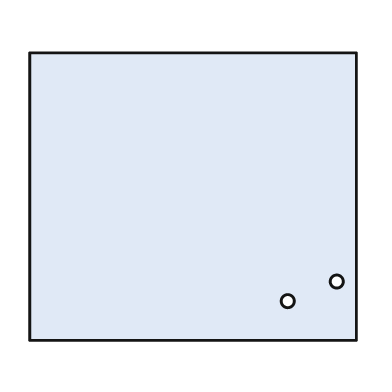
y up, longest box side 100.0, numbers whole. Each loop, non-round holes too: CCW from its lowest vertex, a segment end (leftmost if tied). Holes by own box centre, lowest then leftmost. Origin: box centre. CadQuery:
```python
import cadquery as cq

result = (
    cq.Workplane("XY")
    .moveTo(-50.0, -44.0)
    .lineTo(50.0, -44.0)
    .lineTo(50.0, 44.0)
    .lineTo(-50.0, 44.0)
    .close()
    .moveTo(29.0, -32.0)
    .circle(2.0)
    .moveTo(44.0, -26.0)
    .circle(2.0)
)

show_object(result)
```